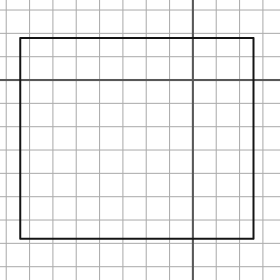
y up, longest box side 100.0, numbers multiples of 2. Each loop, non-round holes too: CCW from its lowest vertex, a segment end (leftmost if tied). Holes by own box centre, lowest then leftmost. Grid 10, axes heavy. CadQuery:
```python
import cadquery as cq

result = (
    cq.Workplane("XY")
    .moveTo(-74.0, -68.0)
    .lineTo(26.0, -68.0)
    .lineTo(26.0, 18.0)
    .lineTo(-74.0, 18.0)
    .close()
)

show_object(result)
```